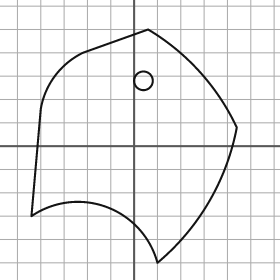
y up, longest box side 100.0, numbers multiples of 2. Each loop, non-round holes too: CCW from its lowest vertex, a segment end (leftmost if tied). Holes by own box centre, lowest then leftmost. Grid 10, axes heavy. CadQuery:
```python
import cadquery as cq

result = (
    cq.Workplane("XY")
    .moveTo(10.0, -50.0)
    .threePointArc((32.0, -24.0), (44.0, 8.0))
    .threePointArc((28.0, 32.0), (6.0, 50.0))
    .lineTo(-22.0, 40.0)
    .threePointArc((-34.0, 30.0), (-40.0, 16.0))
    .lineTo(-44.0, -30.0)
    .threePointArc((-12.0, -26.0), (10.0, -50.0))
    .close()
    .moveTo(4.0, 28.0)
    .circle(4.0)
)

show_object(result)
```